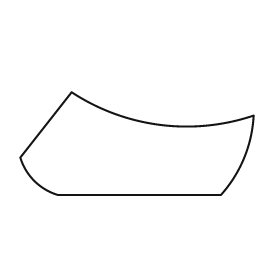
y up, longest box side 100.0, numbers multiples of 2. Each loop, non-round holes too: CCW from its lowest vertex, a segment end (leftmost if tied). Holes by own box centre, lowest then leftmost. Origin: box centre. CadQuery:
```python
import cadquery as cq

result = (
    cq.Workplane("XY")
    .moveTo(-34.0, -22.0)
    .lineTo(36.0, -22.0)
    .threePointArc((46.0, -6.0), (50.0, 12.0))
    .threePointArc((10.0, 8.0), (-28.0, 22.0))
    .lineTo(-50.0, -6.0)
    .threePointArc((-44.0, -16.0), (-34.0, -22.0))
    .close()
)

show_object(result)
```